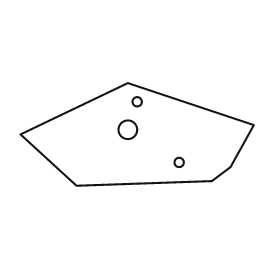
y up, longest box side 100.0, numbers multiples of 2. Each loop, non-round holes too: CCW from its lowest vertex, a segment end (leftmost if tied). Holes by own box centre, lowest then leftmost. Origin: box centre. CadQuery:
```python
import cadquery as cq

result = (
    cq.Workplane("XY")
    .moveTo(-26.0, -22.0)
    .lineTo(32.0, -20.0)
    .lineTo(40.0, -14.0)
    .lineTo(50.0, 4.0)
    .lineTo(-4.0, 22.0)
    .lineTo(-50.0, 0.0)
    .close()
    .moveTo(18.0, -12.0)
    .circle(2.0)
    .moveTo(-4.0, 2.0)
    .circle(4.0)
    .moveTo(0.0, 14.0)
    .circle(2.0)
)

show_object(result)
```